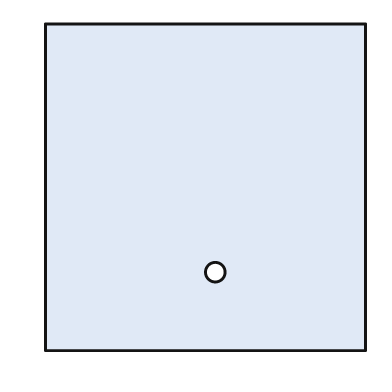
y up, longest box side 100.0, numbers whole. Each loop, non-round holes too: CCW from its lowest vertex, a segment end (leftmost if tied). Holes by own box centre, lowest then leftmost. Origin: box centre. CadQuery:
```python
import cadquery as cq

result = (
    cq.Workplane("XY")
    .moveTo(-49.0, -50.0)
    .lineTo(49.0, -50.0)
    .lineTo(49.0, 50.0)
    .lineTo(-49.0, 50.0)
    .close()
    .moveTo(3.0, -26.0)
    .circle(3.0)
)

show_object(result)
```